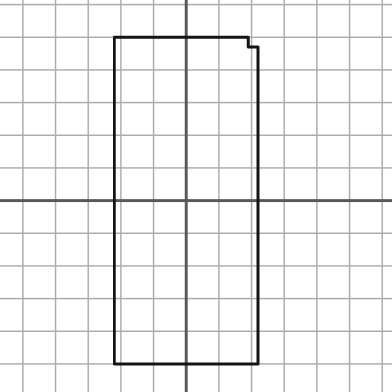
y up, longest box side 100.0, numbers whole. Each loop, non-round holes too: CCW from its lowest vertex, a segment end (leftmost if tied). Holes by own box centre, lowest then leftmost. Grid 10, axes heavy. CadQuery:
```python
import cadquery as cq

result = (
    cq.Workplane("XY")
    .moveTo(-22.0, -50.0)
    .lineTo(22.0, -50.0)
    .lineTo(22.0, 47.0)
    .lineTo(19.0, 47.0)
    .lineTo(19.0, 50.0)
    .lineTo(-22.0, 50.0)
    .close()
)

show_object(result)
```